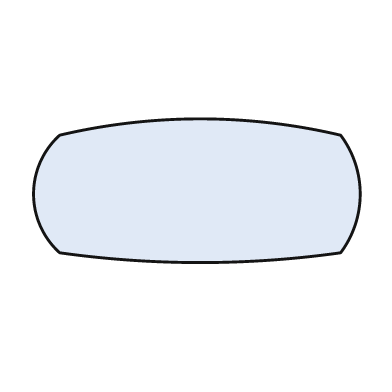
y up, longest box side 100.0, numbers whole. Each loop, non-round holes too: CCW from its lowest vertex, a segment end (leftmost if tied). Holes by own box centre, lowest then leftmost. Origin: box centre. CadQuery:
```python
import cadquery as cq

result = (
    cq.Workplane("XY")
    .moveTo(-42.0, -19.0)
    .threePointArc((1.0, -22.0), (44.0, -19.0))
    .threePointArc((50.0, -1.0), (44.0, 17.0))
    .threePointArc((1.0, 22.0), (-42.0, 17.0))
    .threePointArc((-50.0, -1.0), (-42.0, -19.0))
    .close()
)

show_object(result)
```